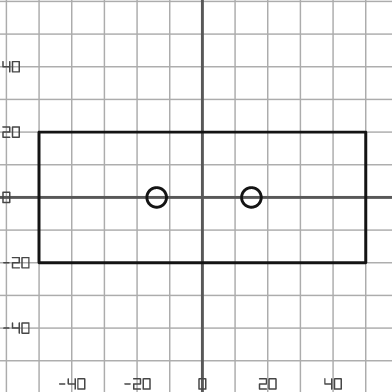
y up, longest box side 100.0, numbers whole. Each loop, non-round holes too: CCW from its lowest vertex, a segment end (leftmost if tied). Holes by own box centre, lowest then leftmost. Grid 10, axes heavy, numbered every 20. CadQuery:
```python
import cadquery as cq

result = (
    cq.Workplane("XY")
    .moveTo(-50.0, -20.0)
    .lineTo(50.0, -20.0)
    .lineTo(50.0, 20.0)
    .lineTo(-50.0, 20.0)
    .close()
    .moveTo(-14.0, 0.0)
    .circle(3.0)
    .moveTo(15.0, 0.0)
    .circle(3.0)
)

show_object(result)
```